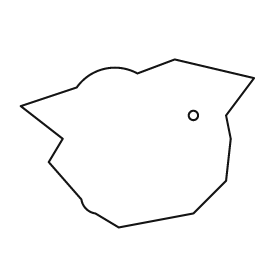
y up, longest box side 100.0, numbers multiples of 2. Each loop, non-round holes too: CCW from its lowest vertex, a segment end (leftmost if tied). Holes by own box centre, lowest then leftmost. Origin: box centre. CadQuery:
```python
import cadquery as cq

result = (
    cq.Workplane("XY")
    .moveTo(-8.0, -36.0)
    .lineTo(24.0, -30.0)
    .lineTo(38.0, -16.0)
    .lineTo(40.0, 2.0)
    .lineTo(38.0, 12.0)
    .lineTo(50.0, 28.0)
    .lineTo(16.0, 36.0)
    .lineTo(0.0, 30.0)
    .threePointArc((-14.0, 32.0), (-26.0, 24.0))
    .lineTo(-50.0, 16.0)
    .lineTo(-32.0, 2.0)
    .lineTo(-38.0, -8.0)
    .lineTo(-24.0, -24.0)
    .threePointArc((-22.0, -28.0), (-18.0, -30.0))
    .close()
    .moveTo(24.0, 12.0)
    .circle(2.0)
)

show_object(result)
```